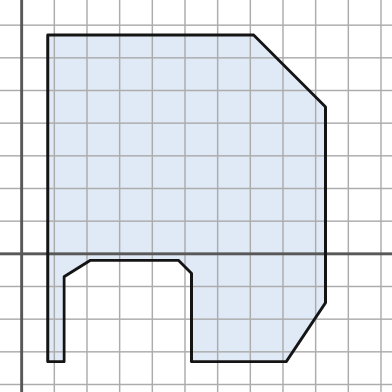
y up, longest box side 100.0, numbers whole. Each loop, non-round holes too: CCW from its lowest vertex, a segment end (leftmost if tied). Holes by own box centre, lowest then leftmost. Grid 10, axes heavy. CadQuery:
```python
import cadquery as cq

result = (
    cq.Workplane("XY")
    .moveTo(8.0, -33.0)
    .lineTo(13.0, -33.0)
    .lineTo(13.0, -7.0)
    .lineTo(21.0, -2.0)
    .lineTo(48.0, -2.0)
    .lineTo(52.0, -6.0)
    .lineTo(52.0, -33.0)
    .lineTo(81.0, -33.0)
    .lineTo(93.0, -15.0)
    .lineTo(93.0, 45.0)
    .lineTo(71.0, 67.0)
    .lineTo(8.0, 67.0)
    .close()
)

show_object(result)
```